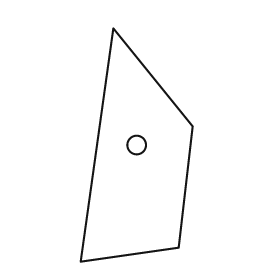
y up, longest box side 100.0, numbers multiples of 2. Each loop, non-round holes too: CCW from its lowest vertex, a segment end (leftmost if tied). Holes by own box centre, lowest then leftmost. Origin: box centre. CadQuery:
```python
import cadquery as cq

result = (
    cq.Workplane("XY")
    .moveTo(-24.0, -50.0)
    .lineTo(18.0, -44.0)
    .lineTo(24.0, 8.0)
    .lineTo(-10.0, 50.0)
    .close()
    .moveTo(0.0, 0.0)
    .circle(4.0)
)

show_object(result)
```